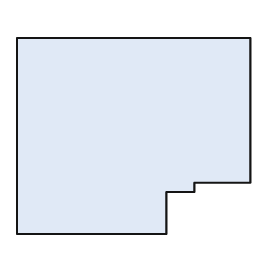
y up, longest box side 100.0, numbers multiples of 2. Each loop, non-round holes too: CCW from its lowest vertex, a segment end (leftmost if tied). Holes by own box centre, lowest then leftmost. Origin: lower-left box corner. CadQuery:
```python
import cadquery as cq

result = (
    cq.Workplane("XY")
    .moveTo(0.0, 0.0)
    .lineTo(64.0, 0.0)
    .lineTo(64.0, 18.0)
    .lineTo(76.0, 18.0)
    .lineTo(76.0, 22.0)
    .lineTo(100.0, 22.0)
    .lineTo(100.0, 84.0)
    .lineTo(0.0, 84.0)
    .close()
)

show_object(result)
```